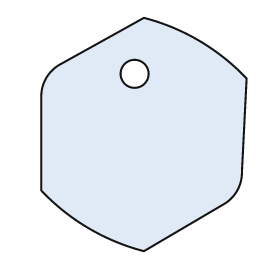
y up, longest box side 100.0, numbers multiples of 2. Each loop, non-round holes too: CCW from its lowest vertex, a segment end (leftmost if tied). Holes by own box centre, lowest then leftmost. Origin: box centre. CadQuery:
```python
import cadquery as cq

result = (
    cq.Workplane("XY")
    .moveTo(0.0, -50.0)
    .lineTo(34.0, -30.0)
    .threePointArc((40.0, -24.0), (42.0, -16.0))
    .lineTo(44.0, 24.0)
    .threePointArc((24.0, 40.0), (0.0, 50.0))
    .lineTo(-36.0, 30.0)
    .threePointArc((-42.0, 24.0), (-44.0, 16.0))
    .lineTo(-44.0, -24.0)
    .threePointArc((-24.0, -40.0), (0.0, -50.0))
    .close()
    .moveTo(-4.0, 26.0)
    .circle(6.0)
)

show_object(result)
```